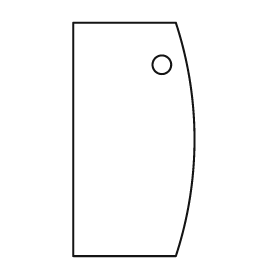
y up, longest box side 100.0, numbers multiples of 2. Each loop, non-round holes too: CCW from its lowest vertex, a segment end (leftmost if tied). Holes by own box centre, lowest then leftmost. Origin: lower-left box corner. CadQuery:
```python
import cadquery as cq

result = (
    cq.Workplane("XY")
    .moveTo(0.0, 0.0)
    .lineTo(44.0, 0.0)
    .threePointArc((52.0, 50.0), (44.0, 100.0))
    .lineTo(0.0, 100.0)
    .close()
    .moveTo(38.0, 82.0)
    .circle(4.0)
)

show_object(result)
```